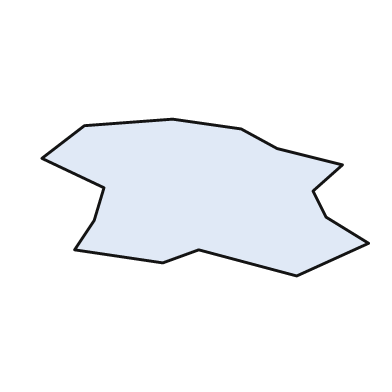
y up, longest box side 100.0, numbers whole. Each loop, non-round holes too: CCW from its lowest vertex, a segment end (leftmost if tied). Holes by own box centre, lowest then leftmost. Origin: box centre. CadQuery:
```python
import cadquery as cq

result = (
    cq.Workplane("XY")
    .moveTo(28.0, -24.0)
    .lineTo(50.0, -14.0)
    .lineTo(37.0, -6.0)
    .lineTo(33.0, 2.0)
    .lineTo(42.0, 10.0)
    .lineTo(22.0, 15.0)
    .lineTo(11.0, 21.0)
    .lineTo(-10.0, 24.0)
    .lineTo(-37.0, 22.0)
    .lineTo(-50.0, 12.0)
    .lineTo(-31.0, 3.0)
    .lineTo(-34.0, -7.0)
    .lineTo(-40.0, -16.0)
    .lineTo(-13.0, -20.0)
    .lineTo(-2.0, -16.0)
    .close()
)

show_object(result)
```